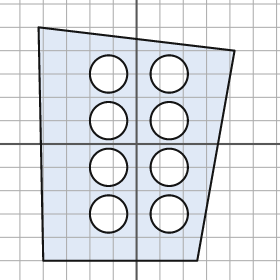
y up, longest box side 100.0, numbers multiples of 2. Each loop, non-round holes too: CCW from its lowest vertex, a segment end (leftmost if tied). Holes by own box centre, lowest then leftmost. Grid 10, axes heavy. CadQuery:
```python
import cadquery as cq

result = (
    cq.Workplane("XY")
    .moveTo(-40.0, -50.0)
    .lineTo(26.0, -50.0)
    .lineTo(42.0, 40.0)
    .lineTo(-42.0, 50.0)
    .close()
    .moveTo(-12.0, -30.0)
    .circle(8.0)
    .moveTo(14.0, -30.0)
    .circle(8.0)
    .moveTo(-12.0, -10.0)
    .circle(8.0)
    .moveTo(14.0, -10.0)
    .circle(8.0)
    .moveTo(-12.0, 10.0)
    .circle(8.0)
    .moveTo(14.0, 10.0)
    .circle(8.0)
    .moveTo(-12.0, 30.0)
    .circle(8.0)
    .moveTo(14.0, 30.0)
    .circle(8.0)
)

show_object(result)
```